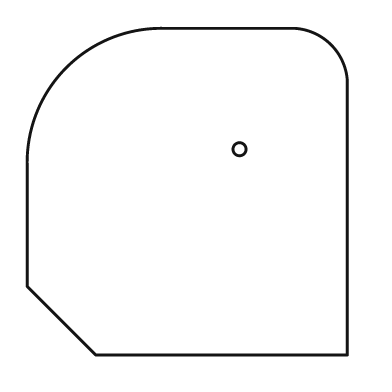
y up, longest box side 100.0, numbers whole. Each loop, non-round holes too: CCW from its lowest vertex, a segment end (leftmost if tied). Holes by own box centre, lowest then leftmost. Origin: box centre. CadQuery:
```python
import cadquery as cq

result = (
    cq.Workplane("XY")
    .moveTo(-28.0, -50.0)
    .lineTo(49.0, -50.0)
    .lineTo(49.0, 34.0)
    .threePointArc((44.0, 45.0), (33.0, 50.0))
    .lineTo(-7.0, 50.0)
    .threePointArc((-37.0, 38.0), (-49.0, 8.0))
    .lineTo(-49.0, -29.0)
    .close()
    .moveTo(16.0, 13.0)
    .circle(2.0)
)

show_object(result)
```